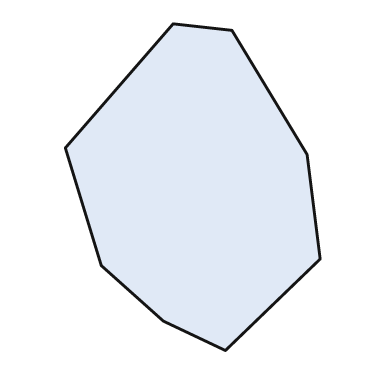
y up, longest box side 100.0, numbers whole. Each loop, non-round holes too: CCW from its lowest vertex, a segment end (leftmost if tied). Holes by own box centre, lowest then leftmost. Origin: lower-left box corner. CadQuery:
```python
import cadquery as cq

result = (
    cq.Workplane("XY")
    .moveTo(49.0, 0.0)
    .lineTo(78.0, 28.0)
    .lineTo(74.0, 60.0)
    .lineTo(51.0, 98.0)
    .lineTo(33.0, 100.0)
    .lineTo(0.0, 62.0)
    .lineTo(11.0, 26.0)
    .lineTo(30.0, 9.0)
    .close()
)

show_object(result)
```